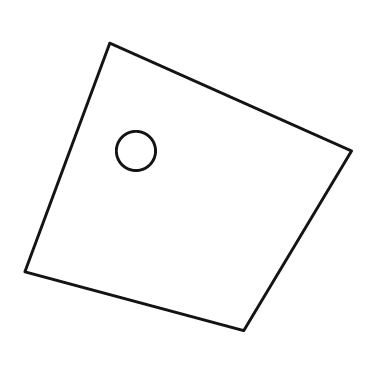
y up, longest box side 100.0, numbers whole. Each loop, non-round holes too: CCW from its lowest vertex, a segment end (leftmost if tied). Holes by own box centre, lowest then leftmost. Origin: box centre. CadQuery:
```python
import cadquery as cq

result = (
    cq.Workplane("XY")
    .moveTo(17.0, -44.0)
    .lineTo(50.0, 11.0)
    .lineTo(-24.0, 44.0)
    .lineTo(-50.0, -26.0)
    .close()
    .moveTo(-16.0, 11.0)
    .circle(6.0)
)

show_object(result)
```